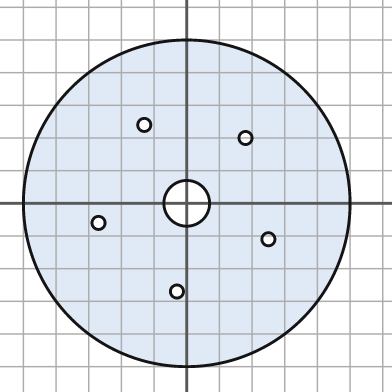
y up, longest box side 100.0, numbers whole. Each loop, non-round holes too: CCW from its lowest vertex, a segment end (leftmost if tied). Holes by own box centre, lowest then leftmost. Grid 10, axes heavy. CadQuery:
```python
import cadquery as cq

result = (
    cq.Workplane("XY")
    .moveTo(0.0, 0.0)
    .circle(50.0)
    .moveTo(-3.0, -27.0)
    .circle(2.0)
    .moveTo(25.0, -11.0)
    .circle(2.0)
    .moveTo(-27.0, -6.0)
    .circle(2.0)
    .moveTo(0.0, 0.0)
    .circle(7.0)
    .moveTo(18.0, 20.0)
    .circle(2.0)
    .moveTo(-13.0, 24.0)
    .circle(2.0)
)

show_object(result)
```